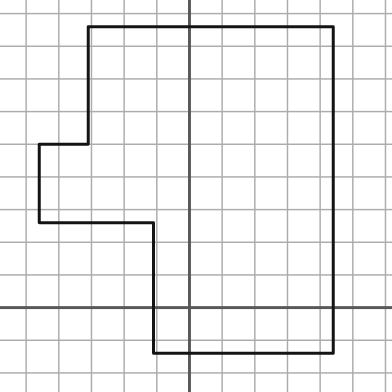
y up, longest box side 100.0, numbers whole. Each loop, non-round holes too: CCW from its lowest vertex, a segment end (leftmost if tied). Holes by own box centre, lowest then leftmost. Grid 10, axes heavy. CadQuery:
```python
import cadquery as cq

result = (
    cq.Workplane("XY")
    .moveTo(-11.0, -14.0)
    .lineTo(44.0, -14.0)
    .lineTo(44.0, 86.0)
    .lineTo(-31.0, 86.0)
    .lineTo(-31.0, 50.0)
    .lineTo(-46.0, 50.0)
    .lineTo(-46.0, 26.0)
    .lineTo(-11.0, 26.0)
    .close()
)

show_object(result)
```